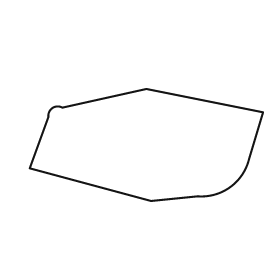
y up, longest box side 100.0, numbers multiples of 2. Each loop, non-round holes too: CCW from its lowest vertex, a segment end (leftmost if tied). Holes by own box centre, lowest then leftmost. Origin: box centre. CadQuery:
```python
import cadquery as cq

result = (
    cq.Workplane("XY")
    .moveTo(2.0, -24.0)
    .lineTo(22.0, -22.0)
    .threePointArc((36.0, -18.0), (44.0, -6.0))
    .lineTo(50.0, 14.0)
    .lineTo(0.0, 24.0)
    .lineTo(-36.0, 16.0)
    .threePointArc((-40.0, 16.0), (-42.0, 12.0))
    .lineTo(-50.0, -10.0)
    .close()
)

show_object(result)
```